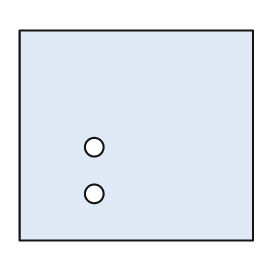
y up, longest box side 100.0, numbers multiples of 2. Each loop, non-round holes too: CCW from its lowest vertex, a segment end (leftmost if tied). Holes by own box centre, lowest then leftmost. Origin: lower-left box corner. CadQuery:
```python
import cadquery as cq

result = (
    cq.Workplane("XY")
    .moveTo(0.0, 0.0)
    .lineTo(100.0, 0.0)
    .lineTo(100.0, 90.0)
    .lineTo(0.0, 90.0)
    .close()
    .moveTo(32.0, 20.0)
    .circle(4.0)
    .moveTo(32.0, 40.0)
    .circle(4.0)
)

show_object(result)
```